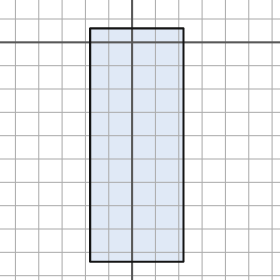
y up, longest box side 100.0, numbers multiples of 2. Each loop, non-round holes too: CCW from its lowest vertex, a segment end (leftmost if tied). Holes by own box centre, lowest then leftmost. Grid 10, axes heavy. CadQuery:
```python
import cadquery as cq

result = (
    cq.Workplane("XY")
    .moveTo(-18.0, -94.0)
    .lineTo(22.0, -94.0)
    .lineTo(22.0, 6.0)
    .lineTo(-18.0, 6.0)
    .close()
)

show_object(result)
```